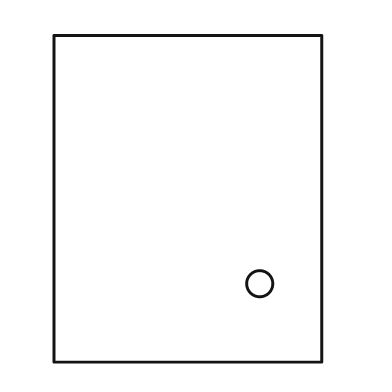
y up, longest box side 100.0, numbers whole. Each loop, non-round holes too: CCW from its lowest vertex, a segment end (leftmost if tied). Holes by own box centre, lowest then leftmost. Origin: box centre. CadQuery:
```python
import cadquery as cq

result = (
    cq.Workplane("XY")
    .moveTo(-41.0, -50.0)
    .lineTo(41.0, -50.0)
    .lineTo(41.0, 50.0)
    .lineTo(-41.0, 50.0)
    .close()
    .moveTo(22.0, -26.0)
    .circle(4.0)
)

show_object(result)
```